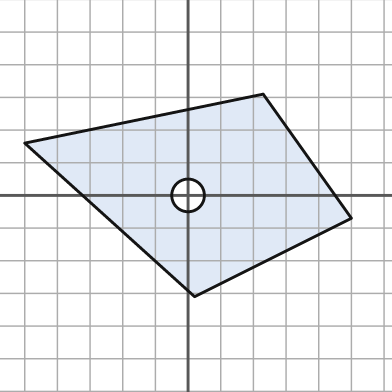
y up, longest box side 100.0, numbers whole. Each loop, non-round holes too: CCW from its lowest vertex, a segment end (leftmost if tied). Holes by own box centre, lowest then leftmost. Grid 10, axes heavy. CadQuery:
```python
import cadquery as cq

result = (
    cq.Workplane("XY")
    .moveTo(2.0, -31.0)
    .lineTo(50.0, -7.0)
    .lineTo(23.0, 31.0)
    .lineTo(-50.0, 16.0)
    .close()
    .moveTo(0.0, 0.0)
    .circle(5.0)
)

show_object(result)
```